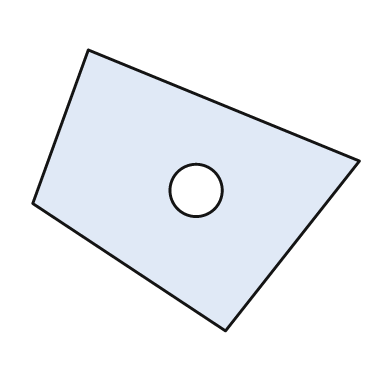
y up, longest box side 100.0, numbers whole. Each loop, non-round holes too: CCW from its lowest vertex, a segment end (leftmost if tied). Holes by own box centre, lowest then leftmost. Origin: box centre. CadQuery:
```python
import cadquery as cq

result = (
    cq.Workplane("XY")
    .moveTo(9.0, -43.0)
    .lineTo(50.0, 9.0)
    .lineTo(-33.0, 43.0)
    .lineTo(-50.0, -4.0)
    .close()
    .moveTo(0.0, 0.0)
    .circle(8.0)
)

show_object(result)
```